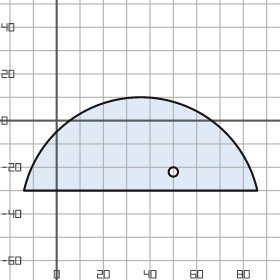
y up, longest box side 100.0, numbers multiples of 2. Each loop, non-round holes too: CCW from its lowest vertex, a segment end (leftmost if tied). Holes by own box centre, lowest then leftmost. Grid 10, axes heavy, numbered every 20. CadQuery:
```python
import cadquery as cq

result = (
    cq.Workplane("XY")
    .moveTo(-14.0, -30.0)
    .lineTo(86.0, -30.0)
    .threePointArc((36.0, 10.0), (-14.0, -30.0))
    .close()
    .moveTo(50.0, -22.0)
    .circle(2.0)
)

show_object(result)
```